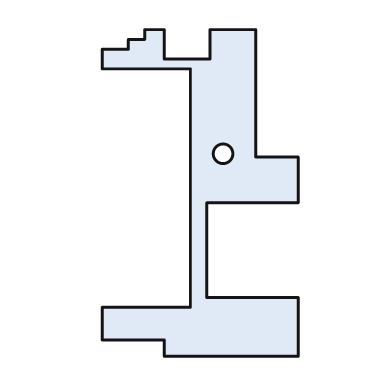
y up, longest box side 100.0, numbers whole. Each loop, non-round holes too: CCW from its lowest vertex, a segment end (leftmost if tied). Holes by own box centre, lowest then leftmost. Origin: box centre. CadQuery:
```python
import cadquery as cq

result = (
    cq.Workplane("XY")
    .moveTo(-11.0, -50.0)
    .lineTo(30.0, -50.0)
    .lineTo(30.0, -32.0)
    .lineTo(2.0, -32.0)
    .lineTo(2.0, -3.0)
    .lineTo(30.0, -3.0)
    .lineTo(30.0, 11.0)
    .lineTo(17.0, 11.0)
    .lineTo(17.0, 50.0)
    .lineTo(3.0, 50.0)
    .lineTo(3.0, 41.0)
    .lineTo(-11.0, 41.0)
    .lineTo(-11.0, 50.0)
    .lineTo(-17.0, 50.0)
    .lineTo(-17.0, 47.0)
    .lineTo(-22.0, 47.0)
    .lineTo(-22.0, 44.0)
    .lineTo(-30.0, 44.0)
    .lineTo(-30.0, 38.0)
    .lineTo(-3.0, 38.0)
    .lineTo(-3.0, -35.0)
    .lineTo(-30.0, -35.0)
    .lineTo(-30.0, -45.0)
    .lineTo(-11.0, -45.0)
    .close()
    .moveTo(7.0, 12.0)
    .circle(3.0)
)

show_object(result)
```